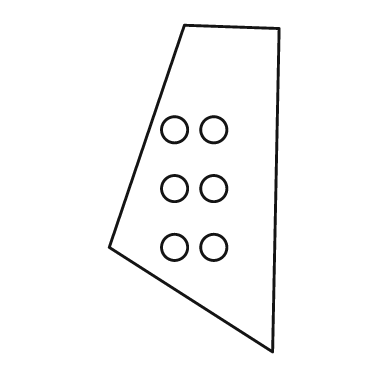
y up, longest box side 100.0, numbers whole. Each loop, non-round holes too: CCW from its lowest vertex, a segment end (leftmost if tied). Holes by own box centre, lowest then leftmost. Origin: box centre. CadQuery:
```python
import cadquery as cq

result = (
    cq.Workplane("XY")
    .moveTo(24.0, -50.0)
    .lineTo(26.0, 49.0)
    .lineTo(-3.0, 50.0)
    .lineTo(-26.0, -18.0)
    .close()
    .moveTo(-6.0, -18.0)
    .circle(4.0)
    .moveTo(6.0, -18.0)
    .circle(4.0)
    .moveTo(-6.0, 0.0)
    .circle(4.0)
    .moveTo(6.0, 0.0)
    .circle(4.0)
    .moveTo(-6.0, 18.0)
    .circle(4.0)
    .moveTo(6.0, 18.0)
    .circle(4.0)
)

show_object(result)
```